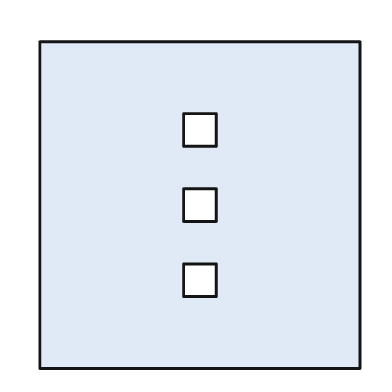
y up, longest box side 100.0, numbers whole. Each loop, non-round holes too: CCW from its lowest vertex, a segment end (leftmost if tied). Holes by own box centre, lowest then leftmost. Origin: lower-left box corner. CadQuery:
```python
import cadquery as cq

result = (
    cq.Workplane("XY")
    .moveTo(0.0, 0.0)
    .lineTo(98.0, 0.0)
    .lineTo(98.0, 100.0)
    .lineTo(0.0, 100.0)
    .close()
    .moveTo(44.0, 22.0)
    .lineTo(54.0, 22.0)
    .lineTo(54.0, 32.0)
    .lineTo(44.0, 32.0)
    .close()
    .moveTo(44.0, 45.0)
    .lineTo(54.0, 45.0)
    .lineTo(54.0, 55.0)
    .lineTo(44.0, 55.0)
    .close()
    .moveTo(44.0, 68.0)
    .lineTo(54.0, 68.0)
    .lineTo(54.0, 78.0)
    .lineTo(44.0, 78.0)
    .close()
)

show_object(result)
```